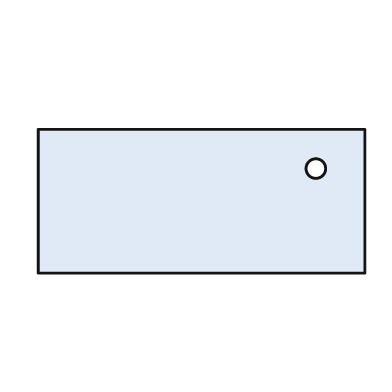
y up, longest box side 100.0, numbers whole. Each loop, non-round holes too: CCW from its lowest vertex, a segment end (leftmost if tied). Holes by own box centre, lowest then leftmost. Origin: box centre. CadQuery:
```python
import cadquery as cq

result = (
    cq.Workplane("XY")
    .moveTo(-50.0, -22.0)
    .lineTo(50.0, -22.0)
    .lineTo(50.0, 22.0)
    .lineTo(-50.0, 22.0)
    .close()
    .moveTo(35.0, 10.0)
    .circle(3.0)
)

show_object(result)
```